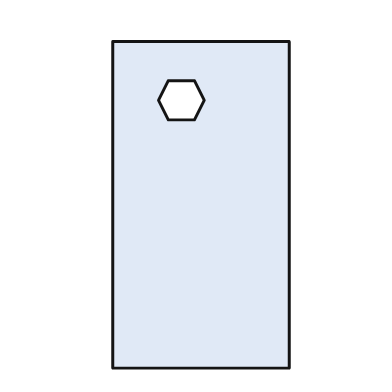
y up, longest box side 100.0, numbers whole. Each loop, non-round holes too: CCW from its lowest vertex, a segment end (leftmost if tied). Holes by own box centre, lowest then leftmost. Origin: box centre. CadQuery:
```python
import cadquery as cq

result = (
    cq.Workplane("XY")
    .moveTo(-27.0, -50.0)
    .lineTo(27.0, -50.0)
    .lineTo(27.0, 50.0)
    .lineTo(-27.0, 50.0)
    .close()
    .moveTo(-10.0, 26.0)
    .lineTo(-2.0, 26.0)
    .lineTo(1.0, 32.0)
    .lineTo(-2.0, 38.0)
    .lineTo(-10.0, 38.0)
    .lineTo(-13.0, 32.0)
    .close()
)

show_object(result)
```